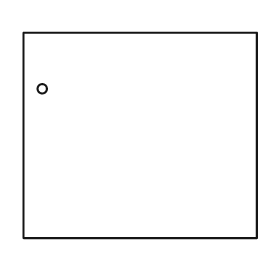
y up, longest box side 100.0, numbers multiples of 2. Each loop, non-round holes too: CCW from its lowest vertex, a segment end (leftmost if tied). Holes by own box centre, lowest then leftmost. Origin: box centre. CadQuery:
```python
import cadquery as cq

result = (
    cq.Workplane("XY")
    .moveTo(-50.0, -44.0)
    .lineTo(50.0, -44.0)
    .lineTo(50.0, 44.0)
    .lineTo(-50.0, 44.0)
    .close()
    .moveTo(-42.0, 20.0)
    .circle(2.0)
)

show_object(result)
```